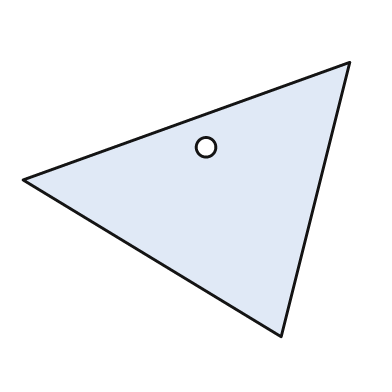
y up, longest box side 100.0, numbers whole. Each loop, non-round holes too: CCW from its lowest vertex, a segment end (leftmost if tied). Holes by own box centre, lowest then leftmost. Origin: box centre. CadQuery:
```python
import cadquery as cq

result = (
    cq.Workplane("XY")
    .moveTo(29.0, -42.0)
    .lineTo(50.0, 42.0)
    .lineTo(-50.0, 6.0)
    .close()
    .moveTo(6.0, 16.0)
    .circle(3.0)
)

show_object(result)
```